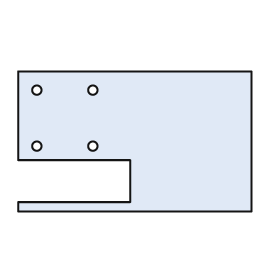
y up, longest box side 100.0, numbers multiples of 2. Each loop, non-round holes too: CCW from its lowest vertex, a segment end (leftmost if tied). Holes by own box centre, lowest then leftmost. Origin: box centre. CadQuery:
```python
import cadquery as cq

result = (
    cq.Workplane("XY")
    .moveTo(-50.0, -30.0)
    .lineTo(50.0, -30.0)
    .lineTo(50.0, 30.0)
    .lineTo(-50.0, 30.0)
    .lineTo(-50.0, -8.0)
    .lineTo(-2.0, -8.0)
    .lineTo(-2.0, -26.0)
    .lineTo(-50.0, -26.0)
    .close()
    .moveTo(-42.0, -2.0)
    .circle(2.0)
    .moveTo(-18.0, -2.0)
    .circle(2.0)
    .moveTo(-42.0, 22.0)
    .circle(2.0)
    .moveTo(-18.0, 22.0)
    .circle(2.0)
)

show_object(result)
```